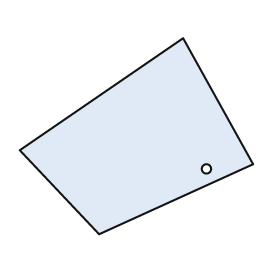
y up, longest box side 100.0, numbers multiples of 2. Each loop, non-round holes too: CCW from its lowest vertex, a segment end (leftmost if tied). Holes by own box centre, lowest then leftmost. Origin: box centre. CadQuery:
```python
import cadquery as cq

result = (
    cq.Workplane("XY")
    .moveTo(-16.0, -42.0)
    .lineTo(50.0, -12.0)
    .lineTo(20.0, 42.0)
    .lineTo(-50.0, -6.0)
    .close()
    .moveTo(30.0, -14.0)
    .circle(2.0)
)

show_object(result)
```